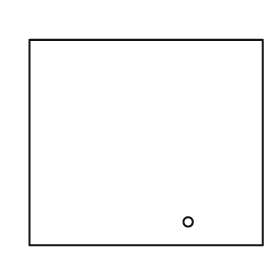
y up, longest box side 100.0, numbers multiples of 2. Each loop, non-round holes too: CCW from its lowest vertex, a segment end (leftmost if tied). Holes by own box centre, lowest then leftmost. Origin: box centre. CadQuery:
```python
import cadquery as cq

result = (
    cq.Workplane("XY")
    .moveTo(-50.0, -44.0)
    .lineTo(50.0, -44.0)
    .lineTo(50.0, 44.0)
    .lineTo(-50.0, 44.0)
    .close()
    .moveTo(18.0, -34.0)
    .circle(2.0)
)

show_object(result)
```